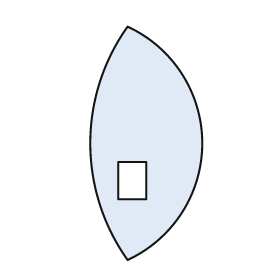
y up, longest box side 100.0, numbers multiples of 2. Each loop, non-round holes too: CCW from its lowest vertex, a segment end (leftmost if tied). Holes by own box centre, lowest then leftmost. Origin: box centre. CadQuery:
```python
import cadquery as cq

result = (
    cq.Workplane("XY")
    .moveTo(-8.0, -50.0)
    .threePointArc((24.0, 0.0), (-8.0, 50.0))
    .threePointArc((-24.0, 0.0), (-8.0, -50.0))
    .close()
    .moveTo(-12.0, -24.0)
    .lineTo(0.0, -24.0)
    .lineTo(0.0, -8.0)
    .lineTo(-12.0, -8.0)
    .close()
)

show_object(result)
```